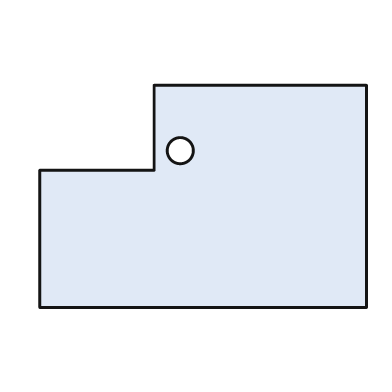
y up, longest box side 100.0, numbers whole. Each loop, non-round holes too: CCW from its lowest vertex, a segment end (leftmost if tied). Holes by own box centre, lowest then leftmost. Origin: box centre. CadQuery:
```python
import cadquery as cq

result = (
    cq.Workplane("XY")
    .moveTo(-50.0, -34.0)
    .lineTo(50.0, -34.0)
    .lineTo(50.0, 34.0)
    .lineTo(-15.0, 34.0)
    .lineTo(-15.0, 8.0)
    .lineTo(-50.0, 8.0)
    .close()
    .moveTo(-7.0, 14.0)
    .circle(4.0)
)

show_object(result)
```